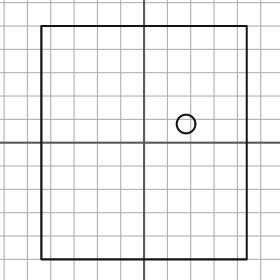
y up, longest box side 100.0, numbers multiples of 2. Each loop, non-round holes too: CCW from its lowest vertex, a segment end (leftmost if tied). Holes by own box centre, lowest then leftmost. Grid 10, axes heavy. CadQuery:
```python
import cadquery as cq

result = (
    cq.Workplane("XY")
    .moveTo(-44.0, -50.0)
    .lineTo(44.0, -50.0)
    .lineTo(44.0, 50.0)
    .lineTo(-44.0, 50.0)
    .close()
    .moveTo(18.0, 8.0)
    .circle(4.0)
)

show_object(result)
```